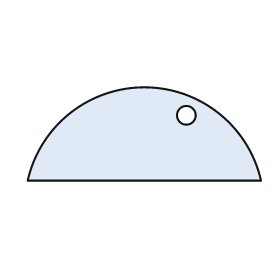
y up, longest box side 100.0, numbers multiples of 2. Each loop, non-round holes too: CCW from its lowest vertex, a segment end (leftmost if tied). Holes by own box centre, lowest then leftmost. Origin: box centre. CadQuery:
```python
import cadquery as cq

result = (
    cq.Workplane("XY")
    .moveTo(-50.0, -20.0)
    .lineTo(50.0, -20.0)
    .threePointArc((0.0, 20.0), (-50.0, -20.0))
    .close()
    .moveTo(18.0, 8.0)
    .circle(4.0)
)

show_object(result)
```